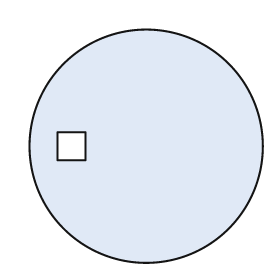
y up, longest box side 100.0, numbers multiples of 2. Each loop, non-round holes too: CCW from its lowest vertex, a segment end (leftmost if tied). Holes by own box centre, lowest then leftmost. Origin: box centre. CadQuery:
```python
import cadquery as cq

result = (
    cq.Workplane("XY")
    .moveTo(0.0, 0.0)
    .circle(50.0)
    .moveTo(-38.0, -6.0)
    .lineTo(-26.0, -6.0)
    .lineTo(-26.0, 6.0)
    .lineTo(-38.0, 6.0)
    .close()
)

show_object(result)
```